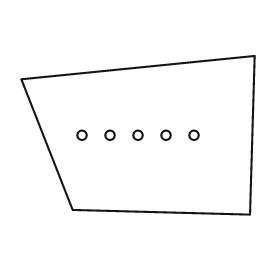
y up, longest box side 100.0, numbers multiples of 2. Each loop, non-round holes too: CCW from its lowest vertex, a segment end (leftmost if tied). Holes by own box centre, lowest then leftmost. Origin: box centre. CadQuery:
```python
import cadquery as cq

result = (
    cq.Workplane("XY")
    .moveTo(48.0, -34.0)
    .lineTo(50.0, 34.0)
    .lineTo(-50.0, 24.0)
    .lineTo(-28.0, -32.0)
    .close()
    .moveTo(-24.0, 0.0)
    .circle(2.0)
    .moveTo(-12.0, 0.0)
    .circle(2.0)
    .moveTo(0.0, 0.0)
    .circle(2.0)
    .moveTo(12.0, 0.0)
    .circle(2.0)
    .moveTo(24.0, 0.0)
    .circle(2.0)
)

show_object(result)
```